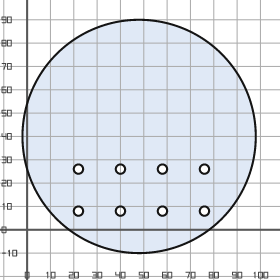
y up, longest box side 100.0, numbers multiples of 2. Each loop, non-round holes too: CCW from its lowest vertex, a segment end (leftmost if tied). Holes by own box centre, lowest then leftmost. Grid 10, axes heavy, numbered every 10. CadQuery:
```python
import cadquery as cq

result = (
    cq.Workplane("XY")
    .moveTo(48.0, 40.0)
    .circle(50.0)
    .moveTo(22.0, 8.0)
    .circle(2.0)
    .moveTo(40.0, 8.0)
    .circle(2.0)
    .moveTo(58.0, 8.0)
    .circle(2.0)
    .moveTo(76.0, 8.0)
    .circle(2.0)
    .moveTo(22.0, 26.0)
    .circle(2.0)
    .moveTo(40.0, 26.0)
    .circle(2.0)
    .moveTo(58.0, 26.0)
    .circle(2.0)
    .moveTo(76.0, 26.0)
    .circle(2.0)
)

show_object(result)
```